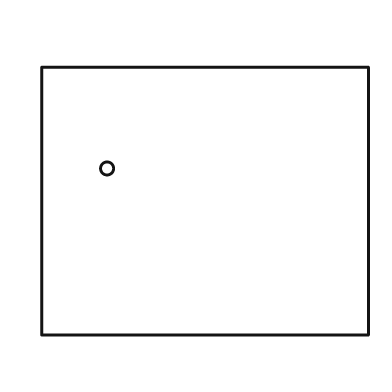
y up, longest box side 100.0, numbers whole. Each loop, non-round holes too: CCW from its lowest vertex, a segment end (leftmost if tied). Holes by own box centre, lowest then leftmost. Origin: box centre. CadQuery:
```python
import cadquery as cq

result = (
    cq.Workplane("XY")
    .moveTo(-50.0, -41.0)
    .lineTo(50.0, -41.0)
    .lineTo(50.0, 41.0)
    .lineTo(-50.0, 41.0)
    .close()
    .moveTo(-30.0, 10.0)
    .circle(2.0)
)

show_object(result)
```